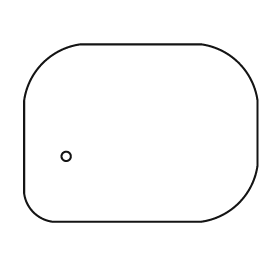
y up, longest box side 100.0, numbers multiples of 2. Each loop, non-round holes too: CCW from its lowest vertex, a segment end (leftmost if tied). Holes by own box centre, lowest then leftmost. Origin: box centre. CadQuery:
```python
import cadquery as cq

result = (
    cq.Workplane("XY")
    .moveTo(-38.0, -38.0)
    .lineTo(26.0, -38.0)
    .threePointArc((42.0, -30.0), (50.0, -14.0))
    .lineTo(50.0, 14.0)
    .threePointArc((42.0, 30.0), (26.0, 38.0))
    .lineTo(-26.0, 38.0)
    .threePointArc((-42.0, 30.0), (-50.0, 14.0))
    .lineTo(-50.0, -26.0)
    .threePointArc((-46.0, -34.0), (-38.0, -38.0))
    .close()
    .moveTo(-32.0, -10.0)
    .circle(2.0)
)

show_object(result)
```